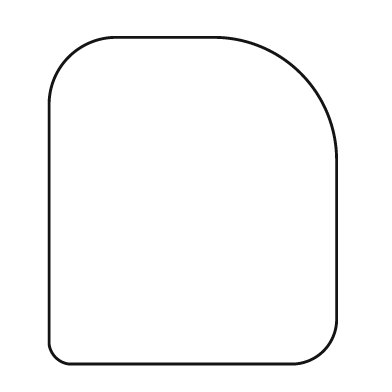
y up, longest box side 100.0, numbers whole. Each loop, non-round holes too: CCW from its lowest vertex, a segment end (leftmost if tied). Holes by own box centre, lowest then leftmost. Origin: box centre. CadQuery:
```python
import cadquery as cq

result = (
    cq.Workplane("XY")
    .moveTo(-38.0, -50.0)
    .lineTo(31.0, -50.0)
    .threePointArc((40.0, -46.0), (44.0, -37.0))
    .lineTo(44.0, 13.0)
    .threePointArc((33.0, 39.0), (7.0, 50.0))
    .lineTo(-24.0, 50.0)
    .threePointArc((-38.0, 44.0), (-44.0, 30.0))
    .lineTo(-44.0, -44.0)
    .threePointArc((-42.0, -48.0), (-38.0, -50.0))
    .close()
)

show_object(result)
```